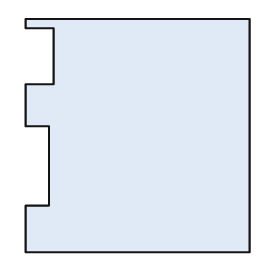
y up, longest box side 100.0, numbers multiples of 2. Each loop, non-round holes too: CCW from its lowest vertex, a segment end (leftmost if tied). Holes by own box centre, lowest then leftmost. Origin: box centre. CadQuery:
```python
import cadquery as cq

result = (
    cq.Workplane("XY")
    .moveTo(-48.0, -50.0)
    .lineTo(48.0, -50.0)
    .lineTo(48.0, 50.0)
    .lineTo(-48.0, 50.0)
    .lineTo(-48.0, 46.0)
    .lineTo(-36.0, 46.0)
    .lineTo(-36.0, 22.0)
    .lineTo(-48.0, 22.0)
    .lineTo(-48.0, 4.0)
    .lineTo(-38.0, 4.0)
    .lineTo(-38.0, -30.0)
    .lineTo(-48.0, -30.0)
    .close()
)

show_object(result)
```